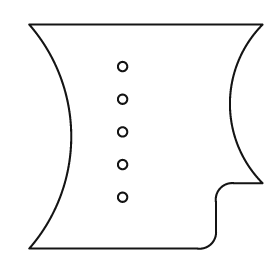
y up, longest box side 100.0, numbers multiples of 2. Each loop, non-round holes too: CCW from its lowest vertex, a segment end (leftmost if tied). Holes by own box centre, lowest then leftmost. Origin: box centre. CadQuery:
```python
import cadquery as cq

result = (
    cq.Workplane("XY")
    .moveTo(-50.0, -48.0)
    .lineTo(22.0, -48.0)
    .threePointArc((28.0, -46.0), (30.0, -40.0))
    .lineTo(30.0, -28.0)
    .threePointArc((32.0, -22.0), (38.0, -20.0))
    .lineTo(50.0, -20.0)
    .threePointArc((36.0, 14.0), (50.0, 48.0))
    .lineTo(-50.0, 48.0)
    .threePointArc((-32.0, 0.0), (-50.0, -48.0))
    .close()
    .moveTo(-10.0, -26.0)
    .circle(2.0)
    .moveTo(-10.0, -12.0)
    .circle(2.0)
    .moveTo(-10.0, 2.0)
    .circle(2.0)
    .moveTo(-10.0, 16.0)
    .circle(2.0)
    .moveTo(-10.0, 30.0)
    .circle(2.0)
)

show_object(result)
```